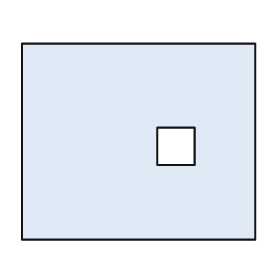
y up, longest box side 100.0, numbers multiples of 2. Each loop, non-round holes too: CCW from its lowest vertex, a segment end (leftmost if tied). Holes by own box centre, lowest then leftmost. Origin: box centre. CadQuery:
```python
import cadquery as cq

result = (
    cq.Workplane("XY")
    .moveTo(-50.0, -42.0)
    .lineTo(50.0, -42.0)
    .lineTo(50.0, 42.0)
    .lineTo(-50.0, 42.0)
    .close()
    .moveTo(8.0, -10.0)
    .lineTo(24.0, -10.0)
    .lineTo(24.0, 6.0)
    .lineTo(8.0, 6.0)
    .close()
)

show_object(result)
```